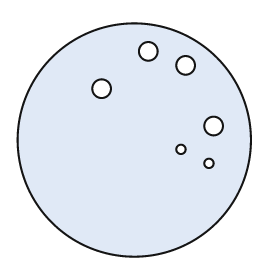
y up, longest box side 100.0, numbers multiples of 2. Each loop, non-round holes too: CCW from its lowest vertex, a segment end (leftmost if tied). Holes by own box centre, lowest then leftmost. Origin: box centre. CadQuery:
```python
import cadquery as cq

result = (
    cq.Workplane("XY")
    .moveTo(0.0, 0.0)
    .circle(50.0)
    .moveTo(32.0, -10.0)
    .circle(2.0)
    .moveTo(20.0, -4.0)
    .circle(2.0)
    .moveTo(34.0, 6.0)
    .circle(4.0)
    .moveTo(-14.0, 22.0)
    .circle(4.0)
    .moveTo(22.0, 32.0)
    .circle(4.0)
    .moveTo(6.0, 38.0)
    .circle(4.0)
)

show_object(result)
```